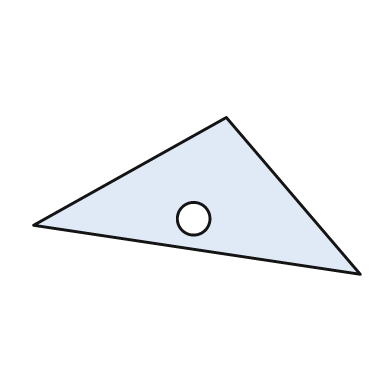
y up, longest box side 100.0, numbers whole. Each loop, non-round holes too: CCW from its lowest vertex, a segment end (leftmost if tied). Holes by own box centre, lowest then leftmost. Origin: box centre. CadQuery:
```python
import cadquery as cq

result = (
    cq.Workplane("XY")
    .moveTo(50.0, -24.0)
    .lineTo(9.0, 24.0)
    .lineTo(-50.0, -9.0)
    .close()
    .moveTo(-1.0, -7.0)
    .circle(5.0)
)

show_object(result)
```